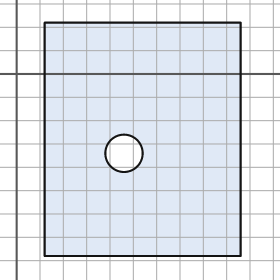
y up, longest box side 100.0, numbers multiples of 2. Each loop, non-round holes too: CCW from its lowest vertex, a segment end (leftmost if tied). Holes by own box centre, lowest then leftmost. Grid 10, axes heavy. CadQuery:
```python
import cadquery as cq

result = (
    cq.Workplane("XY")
    .moveTo(12.0, -78.0)
    .lineTo(96.0, -78.0)
    .lineTo(96.0, 22.0)
    .lineTo(12.0, 22.0)
    .close()
    .moveTo(46.0, -34.0)
    .circle(8.0)
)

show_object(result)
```